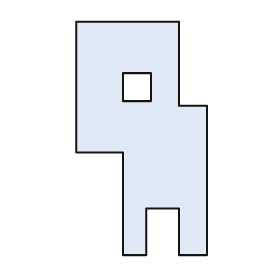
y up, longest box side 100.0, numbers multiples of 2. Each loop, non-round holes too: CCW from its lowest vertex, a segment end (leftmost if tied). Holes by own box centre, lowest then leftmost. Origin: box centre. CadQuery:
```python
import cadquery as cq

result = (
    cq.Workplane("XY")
    .moveTo(-8.0, -50.0)
    .lineTo(2.0, -50.0)
    .lineTo(2.0, -30.0)
    .lineTo(16.0, -30.0)
    .lineTo(16.0, -50.0)
    .lineTo(28.0, -50.0)
    .lineTo(28.0, 14.0)
    .lineTo(16.0, 14.0)
    .lineTo(16.0, 50.0)
    .lineTo(-28.0, 50.0)
    .lineTo(-28.0, -6.0)
    .lineTo(-8.0, -6.0)
    .close()
    .moveTo(-8.0, 16.0)
    .lineTo(4.0, 16.0)
    .lineTo(4.0, 28.0)
    .lineTo(-8.0, 28.0)
    .close()
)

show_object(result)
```